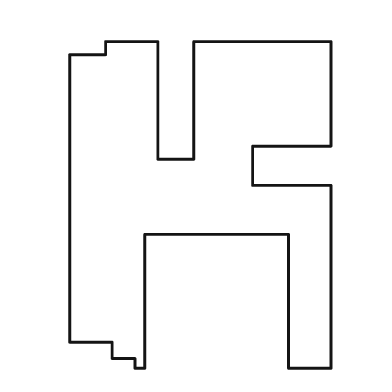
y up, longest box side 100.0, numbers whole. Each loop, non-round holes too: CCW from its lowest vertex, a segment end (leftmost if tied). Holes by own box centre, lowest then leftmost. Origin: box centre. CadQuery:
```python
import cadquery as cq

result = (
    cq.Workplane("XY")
    .moveTo(-20.0, -50.0)
    .lineTo(-17.0, -50.0)
    .lineTo(-17.0, -9.0)
    .lineTo(27.0, -9.0)
    .lineTo(27.0, -50.0)
    .lineTo(40.0, -50.0)
    .lineTo(40.0, 6.0)
    .lineTo(16.0, 6.0)
    .lineTo(16.0, 18.0)
    .lineTo(40.0, 18.0)
    .lineTo(40.0, 50.0)
    .lineTo(-2.0, 50.0)
    .lineTo(-2.0, 14.0)
    .lineTo(-13.0, 14.0)
    .lineTo(-13.0, 50.0)
    .lineTo(-29.0, 50.0)
    .lineTo(-29.0, 46.0)
    .lineTo(-40.0, 46.0)
    .lineTo(-40.0, -42.0)
    .lineTo(-27.0, -42.0)
    .lineTo(-27.0, -47.0)
    .lineTo(-20.0, -47.0)
    .close()
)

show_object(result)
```